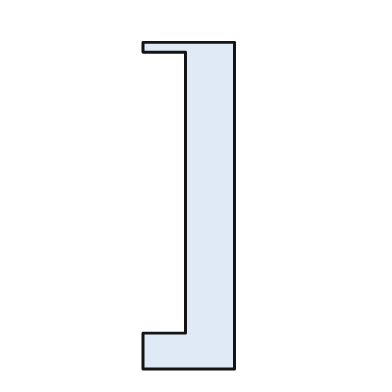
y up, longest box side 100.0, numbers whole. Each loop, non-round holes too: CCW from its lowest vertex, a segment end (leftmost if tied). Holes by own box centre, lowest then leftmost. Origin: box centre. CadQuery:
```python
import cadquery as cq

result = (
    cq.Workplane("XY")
    .moveTo(-14.0, -50.0)
    .lineTo(14.0, -50.0)
    .lineTo(14.0, 50.0)
    .lineTo(-14.0, 50.0)
    .lineTo(-14.0, 47.0)
    .lineTo(-1.0, 47.0)
    .lineTo(-1.0, -39.0)
    .lineTo(-14.0, -39.0)
    .close()
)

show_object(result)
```